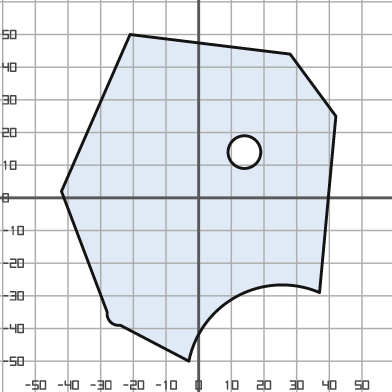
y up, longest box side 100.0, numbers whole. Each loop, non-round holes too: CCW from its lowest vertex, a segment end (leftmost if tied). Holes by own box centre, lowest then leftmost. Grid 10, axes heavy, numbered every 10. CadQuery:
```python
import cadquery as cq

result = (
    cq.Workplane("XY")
    .moveTo(-3.0, -50.0)
    .threePointArc((12.0, -30.0), (37.0, -29.0))
    .lineTo(42.0, 25.0)
    .lineTo(28.0, 44.0)
    .lineTo(-21.0, 50.0)
    .lineTo(-42.0, 2.0)
    .lineTo(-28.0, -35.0)
    .threePointArc((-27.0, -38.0), (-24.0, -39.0))
    .close()
    .moveTo(14.0, 14.0)
    .circle(5.0)
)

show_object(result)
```